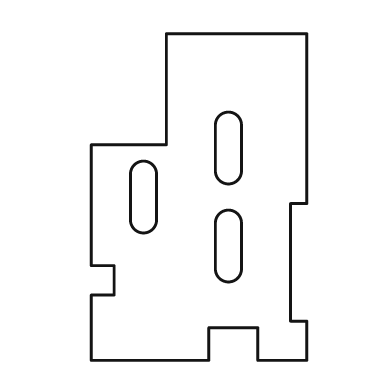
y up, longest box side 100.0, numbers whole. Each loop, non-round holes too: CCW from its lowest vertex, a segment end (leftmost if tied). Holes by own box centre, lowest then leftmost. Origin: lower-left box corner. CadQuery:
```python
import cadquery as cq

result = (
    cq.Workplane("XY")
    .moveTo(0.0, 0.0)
    .lineTo(36.0, 0.0)
    .lineTo(36.0, 10.0)
    .lineTo(51.0, 10.0)
    .lineTo(51.0, 0.0)
    .lineTo(66.0, 0.0)
    .lineTo(66.0, 12.0)
    .lineTo(61.0, 12.0)
    .lineTo(61.0, 48.0)
    .lineTo(66.0, 48.0)
    .lineTo(66.0, 100.0)
    .lineTo(23.0, 100.0)
    .lineTo(23.0, 66.0)
    .lineTo(0.0, 66.0)
    .lineTo(0.0, 29.0)
    .lineTo(7.0, 29.0)
    .lineTo(7.0, 20.0)
    .lineTo(0.0, 20.0)
    .close()
    .moveTo(38.0, 28.0)
    .threePointArc((42.0, 24.0), (46.0, 28.0))
    .lineTo(46.0, 42.0)
    .threePointArc((42.0, 46.0), (38.0, 42.0))
    .close()
    .moveTo(12.0, 43.0)
    .threePointArc((16.0, 39.0), (20.0, 43.0))
    .lineTo(20.0, 57.0)
    .threePointArc((16.0, 61.0), (12.0, 57.0))
    .close()
    .moveTo(38.0, 58.0)
    .threePointArc((42.0, 54.0), (46.0, 58.0))
    .lineTo(46.0, 72.0)
    .threePointArc((42.0, 76.0), (38.0, 72.0))
    .close()
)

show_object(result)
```